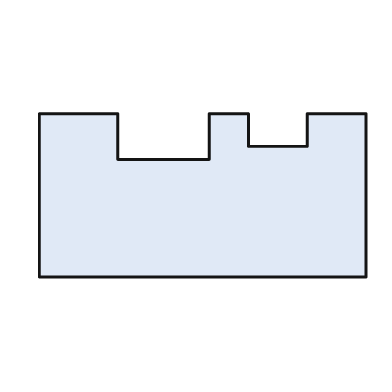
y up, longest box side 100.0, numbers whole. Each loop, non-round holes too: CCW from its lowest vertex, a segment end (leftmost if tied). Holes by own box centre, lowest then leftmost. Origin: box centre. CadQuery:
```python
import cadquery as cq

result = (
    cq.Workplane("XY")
    .moveTo(-50.0, -25.0)
    .lineTo(50.0, -25.0)
    .lineTo(50.0, 25.0)
    .lineTo(32.0, 25.0)
    .lineTo(32.0, 15.0)
    .lineTo(14.0, 15.0)
    .lineTo(14.0, 25.0)
    .lineTo(2.0, 25.0)
    .lineTo(2.0, 11.0)
    .lineTo(-26.0, 11.0)
    .lineTo(-26.0, 25.0)
    .lineTo(-50.0, 25.0)
    .close()
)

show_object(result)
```